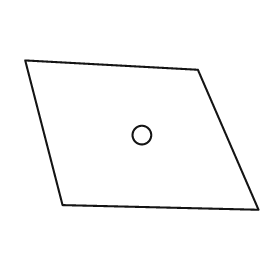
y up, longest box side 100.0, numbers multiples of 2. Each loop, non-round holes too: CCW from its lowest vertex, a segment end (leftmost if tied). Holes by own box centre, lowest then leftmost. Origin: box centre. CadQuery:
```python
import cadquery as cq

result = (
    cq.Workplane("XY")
    .moveTo(50.0, -32.0)
    .lineTo(24.0, 28.0)
    .lineTo(-50.0, 32.0)
    .lineTo(-34.0, -30.0)
    .close()
    .moveTo(0.0, 0.0)
    .circle(4.0)
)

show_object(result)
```